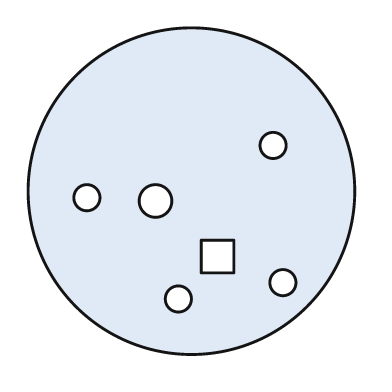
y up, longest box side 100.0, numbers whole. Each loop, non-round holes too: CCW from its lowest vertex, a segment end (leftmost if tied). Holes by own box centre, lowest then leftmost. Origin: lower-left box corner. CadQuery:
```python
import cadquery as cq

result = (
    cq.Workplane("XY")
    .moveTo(50.0, 50.0)
    .circle(50.0)
    .moveTo(46.0, 17.0)
    .circle(4.0)
    .moveTo(78.0, 22.0)
    .circle(4.0)
    .moveTo(53.0, 25.0)
    .lineTo(63.0, 25.0)
    .lineTo(63.0, 35.0)
    .lineTo(53.0, 35.0)
    .close()
    .moveTo(39.0, 47.0)
    .circle(5.0)
    .moveTo(18.0, 48.0)
    .circle(4.0)
    .moveTo(75.0, 64.0)
    .circle(4.0)
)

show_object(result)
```